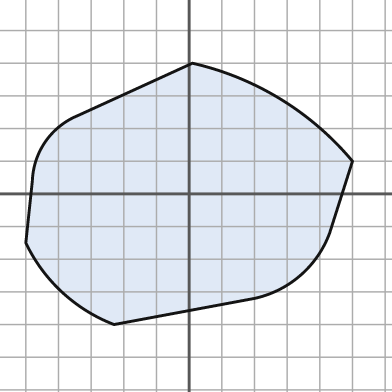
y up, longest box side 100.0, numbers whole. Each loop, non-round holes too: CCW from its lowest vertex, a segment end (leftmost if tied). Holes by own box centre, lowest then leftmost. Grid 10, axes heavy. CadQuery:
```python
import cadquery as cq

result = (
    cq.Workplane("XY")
    .moveTo(-23.0, -40.0)
    .lineTo(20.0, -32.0)
    .threePointArc((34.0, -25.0), (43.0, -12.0))
    .lineTo(50.0, 10.0)
    .threePointArc((28.0, 29.0), (1.0, 40.0))
    .lineTo(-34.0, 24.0)
    .threePointArc((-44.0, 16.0), (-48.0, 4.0))
    .lineTo(-50.0, -15.0)
    .threePointArc((-39.0, -30.0), (-23.0, -40.0))
    .close()
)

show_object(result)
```